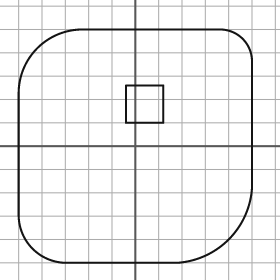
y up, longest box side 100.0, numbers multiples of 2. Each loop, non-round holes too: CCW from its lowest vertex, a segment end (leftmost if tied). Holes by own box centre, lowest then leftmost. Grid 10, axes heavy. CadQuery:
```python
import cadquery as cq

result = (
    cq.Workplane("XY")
    .moveTo(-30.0, -50.0)
    .lineTo(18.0, -50.0)
    .threePointArc((40.0, -40.0), (50.0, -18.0))
    .lineTo(50.0, 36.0)
    .threePointArc((46.0, 46.0), (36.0, 50.0))
    .lineTo(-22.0, 50.0)
    .threePointArc((-42.0, 42.0), (-50.0, 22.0))
    .lineTo(-50.0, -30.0)
    .threePointArc((-44.0, -44.0), (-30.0, -50.0))
    .close()
    .moveTo(-4.0, 10.0)
    .lineTo(12.0, 10.0)
    .lineTo(12.0, 26.0)
    .lineTo(-4.0, 26.0)
    .close()
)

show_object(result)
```